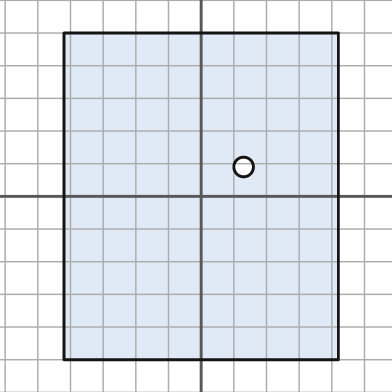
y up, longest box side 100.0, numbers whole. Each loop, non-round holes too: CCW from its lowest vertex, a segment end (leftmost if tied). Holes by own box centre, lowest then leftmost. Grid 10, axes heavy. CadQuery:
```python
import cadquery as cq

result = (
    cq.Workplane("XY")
    .moveTo(-42.0, -50.0)
    .lineTo(42.0, -50.0)
    .lineTo(42.0, 50.0)
    .lineTo(-42.0, 50.0)
    .close()
    .moveTo(13.0, 9.0)
    .circle(3.0)
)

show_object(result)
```